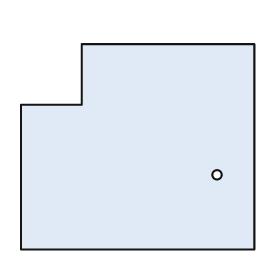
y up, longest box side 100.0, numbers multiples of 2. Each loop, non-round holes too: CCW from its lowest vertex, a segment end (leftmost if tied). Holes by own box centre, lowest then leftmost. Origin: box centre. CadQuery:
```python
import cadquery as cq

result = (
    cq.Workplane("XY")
    .moveTo(-50.0, -44.0)
    .lineTo(50.0, -44.0)
    .lineTo(50.0, 44.0)
    .lineTo(-24.0, 44.0)
    .lineTo(-24.0, 18.0)
    .lineTo(-50.0, 18.0)
    .close()
    .moveTo(34.0, -12.0)
    .circle(2.0)
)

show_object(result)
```